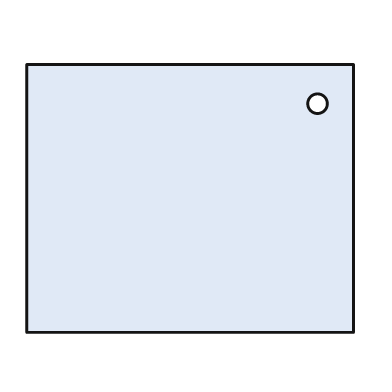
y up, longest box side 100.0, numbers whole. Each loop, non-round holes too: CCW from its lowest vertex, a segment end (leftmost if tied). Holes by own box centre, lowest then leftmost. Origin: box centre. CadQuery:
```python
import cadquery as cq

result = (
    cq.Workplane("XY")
    .moveTo(-50.0, -41.0)
    .lineTo(50.0, -41.0)
    .lineTo(50.0, 41.0)
    .lineTo(-50.0, 41.0)
    .close()
    .moveTo(39.0, 29.0)
    .circle(3.0)
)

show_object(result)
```